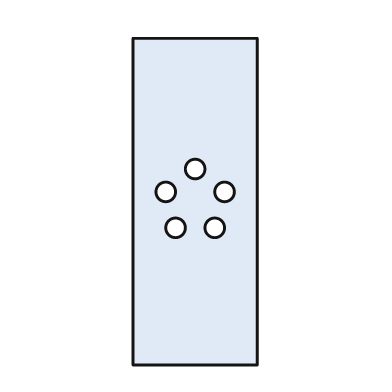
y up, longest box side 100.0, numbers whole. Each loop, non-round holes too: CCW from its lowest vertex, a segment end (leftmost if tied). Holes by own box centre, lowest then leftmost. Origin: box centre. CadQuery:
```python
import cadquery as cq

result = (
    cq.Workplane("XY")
    .moveTo(-19.0, -50.0)
    .lineTo(19.0, -50.0)
    .lineTo(19.0, 50.0)
    .lineTo(-19.0, 50.0)
    .close()
    .moveTo(-6.0, -8.0)
    .circle(3.0)
    .moveTo(6.0, -8.0)
    .circle(3.0)
    .moveTo(-9.0, 3.0)
    .circle(3.0)
    .moveTo(9.0, 3.0)
    .circle(3.0)
    .moveTo(0.0, 10.0)
    .circle(3.0)
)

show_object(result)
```